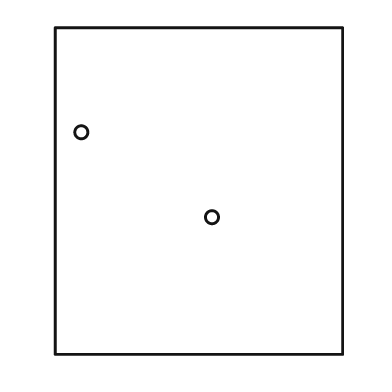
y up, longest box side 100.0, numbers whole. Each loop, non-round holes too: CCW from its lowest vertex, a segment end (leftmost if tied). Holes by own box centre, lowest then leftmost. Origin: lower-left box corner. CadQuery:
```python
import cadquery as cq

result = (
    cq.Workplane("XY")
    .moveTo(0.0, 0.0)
    .lineTo(88.0, 0.0)
    .lineTo(88.0, 100.0)
    .lineTo(0.0, 100.0)
    .close()
    .moveTo(48.0, 42.0)
    .circle(2.0)
    .moveTo(8.0, 68.0)
    .circle(2.0)
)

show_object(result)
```